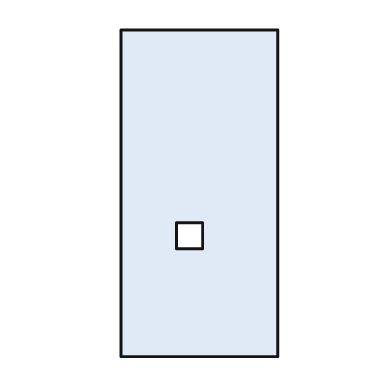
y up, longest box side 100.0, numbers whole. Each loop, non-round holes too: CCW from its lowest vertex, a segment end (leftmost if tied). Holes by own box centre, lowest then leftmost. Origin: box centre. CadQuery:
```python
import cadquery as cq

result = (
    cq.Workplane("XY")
    .moveTo(-24.0, -50.0)
    .lineTo(24.0, -50.0)
    .lineTo(24.0, 50.0)
    .lineTo(-24.0, 50.0)
    .close()
    .moveTo(-7.0, -17.0)
    .lineTo(1.0, -17.0)
    .lineTo(1.0, -9.0)
    .lineTo(-7.0, -9.0)
    .close()
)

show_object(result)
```